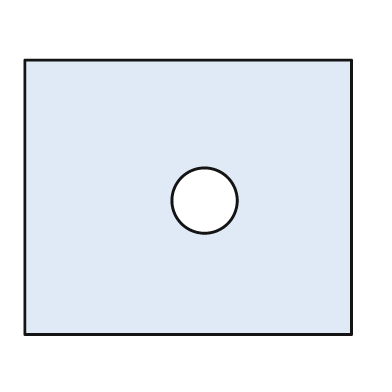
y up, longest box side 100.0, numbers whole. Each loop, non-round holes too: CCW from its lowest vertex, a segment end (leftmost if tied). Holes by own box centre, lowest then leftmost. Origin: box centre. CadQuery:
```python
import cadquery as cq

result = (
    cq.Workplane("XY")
    .moveTo(-50.0, -42.0)
    .lineTo(50.0, -42.0)
    .lineTo(50.0, 42.0)
    .lineTo(-50.0, 42.0)
    .close()
    .moveTo(5.0, -1.0)
    .circle(10.0)
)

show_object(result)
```